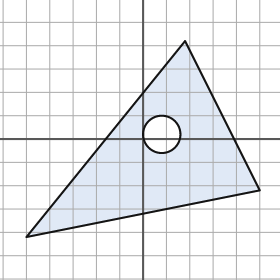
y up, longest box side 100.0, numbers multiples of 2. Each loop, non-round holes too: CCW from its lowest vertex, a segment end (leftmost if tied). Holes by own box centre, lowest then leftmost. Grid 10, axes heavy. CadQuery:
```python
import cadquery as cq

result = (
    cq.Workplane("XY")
    .moveTo(-50.0, -42.0)
    .lineTo(50.0, -22.0)
    .lineTo(18.0, 42.0)
    .close()
    .moveTo(8.0, 2.0)
    .circle(8.0)
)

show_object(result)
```